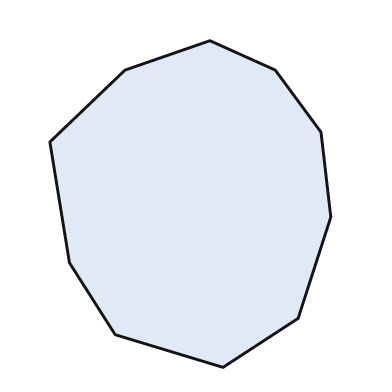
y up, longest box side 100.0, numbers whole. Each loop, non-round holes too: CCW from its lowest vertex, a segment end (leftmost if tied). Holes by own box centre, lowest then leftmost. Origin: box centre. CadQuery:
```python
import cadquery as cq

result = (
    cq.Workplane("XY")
    .moveTo(10.0, -50.0)
    .lineTo(33.0, -35.0)
    .lineTo(43.0, -4.0)
    .lineTo(40.0, 22.0)
    .lineTo(26.0, 41.0)
    .lineTo(6.0, 50.0)
    .lineTo(-20.0, 41.0)
    .lineTo(-43.0, 19.0)
    .lineTo(-37.0, -18.0)
    .lineTo(-23.0, -40.0)
    .close()
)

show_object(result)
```